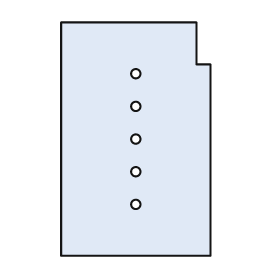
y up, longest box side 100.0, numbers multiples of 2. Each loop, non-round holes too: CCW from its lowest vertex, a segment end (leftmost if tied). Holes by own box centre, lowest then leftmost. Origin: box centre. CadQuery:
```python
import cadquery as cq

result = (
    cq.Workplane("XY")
    .moveTo(-32.0, -50.0)
    .lineTo(32.0, -50.0)
    .lineTo(32.0, 32.0)
    .lineTo(26.0, 32.0)
    .lineTo(26.0, 50.0)
    .lineTo(-32.0, 50.0)
    .close()
    .moveTo(0.0, -28.0)
    .circle(2.0)
    .moveTo(0.0, -14.0)
    .circle(2.0)
    .moveTo(0.0, 0.0)
    .circle(2.0)
    .moveTo(0.0, 14.0)
    .circle(2.0)
    .moveTo(0.0, 28.0)
    .circle(2.0)
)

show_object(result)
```